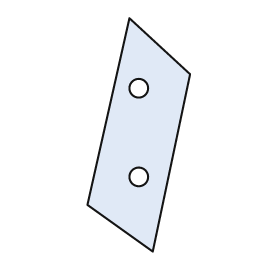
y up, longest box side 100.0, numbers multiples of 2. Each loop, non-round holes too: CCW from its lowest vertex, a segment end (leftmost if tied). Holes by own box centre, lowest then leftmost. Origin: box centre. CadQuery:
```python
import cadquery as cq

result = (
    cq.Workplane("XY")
    .moveTo(6.0, -50.0)
    .lineTo(22.0, 26.0)
    .lineTo(-4.0, 50.0)
    .lineTo(-22.0, -30.0)
    .close()
    .moveTo(0.0, -18.0)
    .circle(4.0)
    .moveTo(0.0, 20.0)
    .circle(4.0)
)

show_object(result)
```